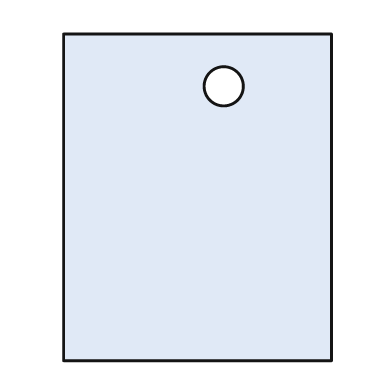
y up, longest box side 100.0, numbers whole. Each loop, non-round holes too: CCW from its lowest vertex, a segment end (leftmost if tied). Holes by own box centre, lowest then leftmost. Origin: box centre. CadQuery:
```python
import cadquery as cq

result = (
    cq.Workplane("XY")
    .moveTo(-41.0, -50.0)
    .lineTo(41.0, -50.0)
    .lineTo(41.0, 50.0)
    .lineTo(-41.0, 50.0)
    .close()
    .moveTo(8.0, 34.0)
    .circle(6.0)
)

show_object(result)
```